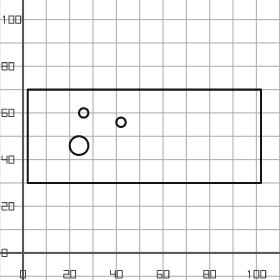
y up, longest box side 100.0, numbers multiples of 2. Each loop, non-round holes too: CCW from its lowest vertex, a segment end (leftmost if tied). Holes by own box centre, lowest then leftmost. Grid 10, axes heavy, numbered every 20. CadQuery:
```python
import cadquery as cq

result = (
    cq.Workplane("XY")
    .moveTo(2.0, 30.0)
    .lineTo(102.0, 30.0)
    .lineTo(102.0, 70.0)
    .lineTo(2.0, 70.0)
    .close()
    .moveTo(24.0, 46.0)
    .circle(4.0)
    .moveTo(42.0, 56.0)
    .circle(2.0)
    .moveTo(26.0, 60.0)
    .circle(2.0)
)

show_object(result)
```